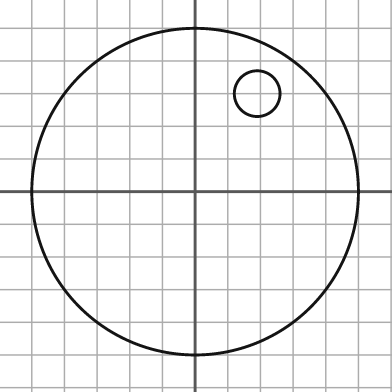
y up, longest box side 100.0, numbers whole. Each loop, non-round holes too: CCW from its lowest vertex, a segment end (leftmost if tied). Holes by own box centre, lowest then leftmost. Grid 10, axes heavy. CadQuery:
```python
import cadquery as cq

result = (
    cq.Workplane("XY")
    .moveTo(0.0, 0.0)
    .circle(50.0)
    .moveTo(19.0, 30.0)
    .circle(7.0)
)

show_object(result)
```